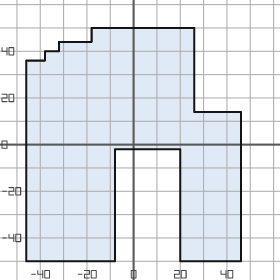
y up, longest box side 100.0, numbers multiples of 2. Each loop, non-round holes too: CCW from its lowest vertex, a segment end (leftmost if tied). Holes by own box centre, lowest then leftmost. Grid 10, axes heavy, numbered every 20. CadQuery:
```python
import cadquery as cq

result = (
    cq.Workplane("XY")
    .moveTo(-46.0, -50.0)
    .lineTo(-8.0, -50.0)
    .lineTo(-8.0, -2.0)
    .lineTo(20.0, -2.0)
    .lineTo(20.0, -50.0)
    .lineTo(46.0, -50.0)
    .lineTo(46.0, 14.0)
    .lineTo(26.0, 14.0)
    .lineTo(26.0, 50.0)
    .lineTo(-18.0, 50.0)
    .lineTo(-18.0, 44.0)
    .lineTo(-32.0, 44.0)
    .lineTo(-32.0, 40.0)
    .lineTo(-38.0, 40.0)
    .lineTo(-38.0, 36.0)
    .lineTo(-46.0, 36.0)
    .close()
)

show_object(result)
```